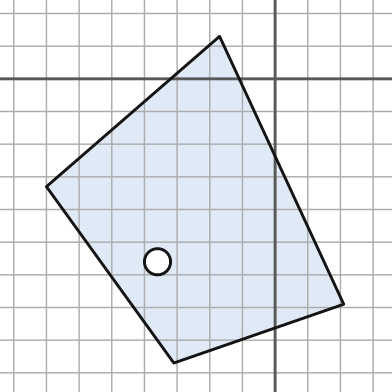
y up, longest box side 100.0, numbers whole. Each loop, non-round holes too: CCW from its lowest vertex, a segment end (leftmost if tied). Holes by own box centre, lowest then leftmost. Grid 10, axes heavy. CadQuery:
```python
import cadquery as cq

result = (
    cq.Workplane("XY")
    .moveTo(-31.0, -87.0)
    .lineTo(21.0, -69.0)
    .lineTo(-17.0, 13.0)
    .lineTo(-70.0, -33.0)
    .close()
    .moveTo(-36.0, -56.0)
    .circle(4.0)
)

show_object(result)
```